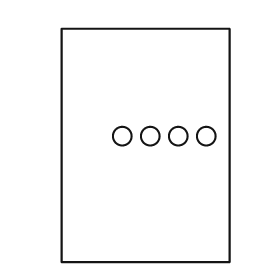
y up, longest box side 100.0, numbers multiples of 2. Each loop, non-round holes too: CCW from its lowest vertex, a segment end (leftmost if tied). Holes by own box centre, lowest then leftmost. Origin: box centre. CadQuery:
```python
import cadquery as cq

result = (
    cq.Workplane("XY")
    .moveTo(-36.0, -50.0)
    .lineTo(36.0, -50.0)
    .lineTo(36.0, 50.0)
    .lineTo(-36.0, 50.0)
    .close()
    .moveTo(-10.0, 4.0)
    .circle(4.0)
    .moveTo(2.0, 4.0)
    .circle(4.0)
    .moveTo(14.0, 4.0)
    .circle(4.0)
    .moveTo(26.0, 4.0)
    .circle(4.0)
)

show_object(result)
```